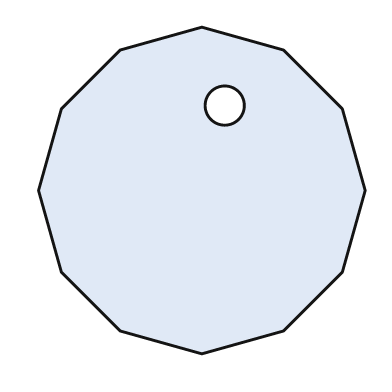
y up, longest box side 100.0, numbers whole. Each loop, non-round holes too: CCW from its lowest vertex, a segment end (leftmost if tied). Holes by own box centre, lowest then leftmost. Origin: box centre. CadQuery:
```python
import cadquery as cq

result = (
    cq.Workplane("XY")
    .moveTo(0.0, -50.0)
    .lineTo(25.0, -43.0)
    .lineTo(43.0, -25.0)
    .lineTo(50.0, 0.0)
    .lineTo(43.0, 25.0)
    .lineTo(25.0, 43.0)
    .lineTo(0.0, 50.0)
    .lineTo(-25.0, 43.0)
    .lineTo(-43.0, 25.0)
    .lineTo(-50.0, 0.0)
    .lineTo(-43.0, -25.0)
    .lineTo(-25.0, -43.0)
    .close()
    .moveTo(7.0, 26.0)
    .circle(6.0)
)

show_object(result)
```